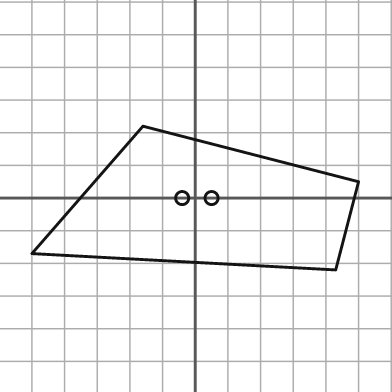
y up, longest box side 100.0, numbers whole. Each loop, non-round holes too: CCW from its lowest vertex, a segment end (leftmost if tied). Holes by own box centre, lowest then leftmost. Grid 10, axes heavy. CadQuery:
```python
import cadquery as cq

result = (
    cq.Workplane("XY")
    .moveTo(43.0, -22.0)
    .lineTo(50.0, 5.0)
    .lineTo(-16.0, 22.0)
    .lineTo(-50.0, -17.0)
    .close()
    .moveTo(-4.0, 0.0)
    .circle(2.0)
    .moveTo(5.0, 0.0)
    .circle(2.0)
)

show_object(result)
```